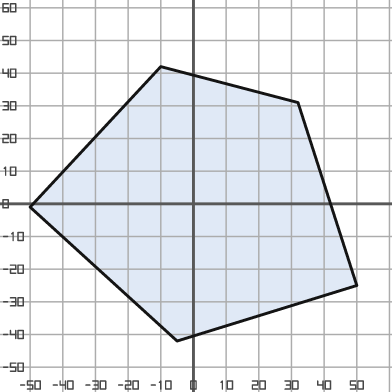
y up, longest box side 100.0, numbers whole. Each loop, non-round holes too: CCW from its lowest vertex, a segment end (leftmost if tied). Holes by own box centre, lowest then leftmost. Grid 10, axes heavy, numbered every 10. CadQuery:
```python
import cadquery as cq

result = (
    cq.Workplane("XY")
    .moveTo(-5.0, -42.0)
    .lineTo(50.0, -25.0)
    .lineTo(32.0, 31.0)
    .lineTo(-10.0, 42.0)
    .lineTo(-50.0, -1.0)
    .close()
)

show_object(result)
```